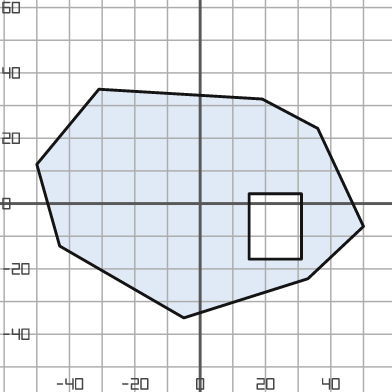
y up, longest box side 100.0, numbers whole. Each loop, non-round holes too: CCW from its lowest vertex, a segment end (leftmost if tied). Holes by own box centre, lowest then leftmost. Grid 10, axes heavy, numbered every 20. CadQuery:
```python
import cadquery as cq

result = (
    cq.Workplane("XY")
    .moveTo(-5.0, -35.0)
    .lineTo(33.0, -23.0)
    .lineTo(50.0, -7.0)
    .lineTo(36.0, 23.0)
    .lineTo(19.0, 32.0)
    .lineTo(-31.0, 35.0)
    .lineTo(-50.0, 12.0)
    .lineTo(-43.0, -13.0)
    .close()
    .moveTo(15.0, -17.0)
    .lineTo(31.0, -17.0)
    .lineTo(31.0, 3.0)
    .lineTo(15.0, 3.0)
    .close()
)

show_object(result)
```